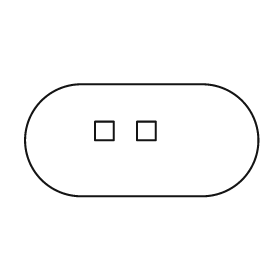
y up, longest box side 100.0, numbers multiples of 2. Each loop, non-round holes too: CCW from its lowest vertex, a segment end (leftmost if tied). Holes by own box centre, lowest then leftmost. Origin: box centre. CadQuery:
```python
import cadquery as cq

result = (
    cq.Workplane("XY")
    .moveTo(-26.0, -24.0)
    .lineTo(26.0, -24.0)
    .threePointArc((50.0, 0.0), (26.0, 24.0))
    .lineTo(-26.0, 24.0)
    .threePointArc((-50.0, 0.0), (-26.0, -24.0))
    .close()
    .moveTo(-20.0, 0.0)
    .lineTo(-12.0, 0.0)
    .lineTo(-12.0, 8.0)
    .lineTo(-20.0, 8.0)
    .close()
    .moveTo(-2.0, 0.0)
    .lineTo(6.0, 0.0)
    .lineTo(6.0, 8.0)
    .lineTo(-2.0, 8.0)
    .close()
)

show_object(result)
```